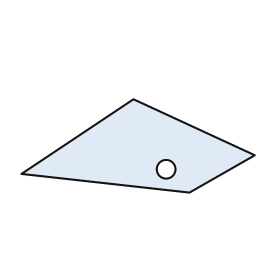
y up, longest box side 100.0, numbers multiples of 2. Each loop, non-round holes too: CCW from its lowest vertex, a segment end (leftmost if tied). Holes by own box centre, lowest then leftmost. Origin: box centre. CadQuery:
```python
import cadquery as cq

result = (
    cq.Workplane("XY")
    .moveTo(22.0, -20.0)
    .lineTo(50.0, -4.0)
    .lineTo(-2.0, 20.0)
    .lineTo(-50.0, -12.0)
    .close()
    .moveTo(12.0, -10.0)
    .circle(4.0)
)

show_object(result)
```